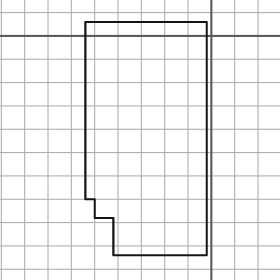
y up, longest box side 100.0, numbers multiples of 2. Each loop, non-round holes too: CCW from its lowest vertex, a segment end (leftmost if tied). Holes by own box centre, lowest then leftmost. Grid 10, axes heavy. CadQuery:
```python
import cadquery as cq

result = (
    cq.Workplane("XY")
    .moveTo(-42.0, -94.0)
    .lineTo(-2.0, -94.0)
    .lineTo(-2.0, 6.0)
    .lineTo(-54.0, 6.0)
    .lineTo(-54.0, -70.0)
    .lineTo(-50.0, -70.0)
    .lineTo(-50.0, -78.0)
    .lineTo(-42.0, -78.0)
    .close()
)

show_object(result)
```